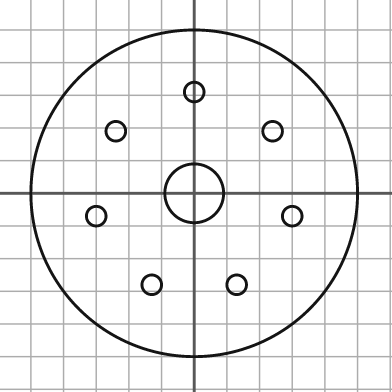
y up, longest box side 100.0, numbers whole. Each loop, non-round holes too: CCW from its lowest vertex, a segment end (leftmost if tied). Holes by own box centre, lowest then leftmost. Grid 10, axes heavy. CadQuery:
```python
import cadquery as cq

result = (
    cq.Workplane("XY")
    .moveTo(0.0, 0.0)
    .circle(50.0)
    .moveTo(-13.0, -28.0)
    .circle(3.0)
    .moveTo(13.0, -28.0)
    .circle(3.0)
    .moveTo(-30.0, -7.0)
    .circle(3.0)
    .moveTo(30.0, -7.0)
    .circle(3.0)
    .moveTo(0.0, 0.0)
    .circle(9.0)
    .moveTo(-24.0, 19.0)
    .circle(3.0)
    .moveTo(24.0, 19.0)
    .circle(3.0)
    .moveTo(0.0, 31.0)
    .circle(3.0)
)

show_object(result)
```